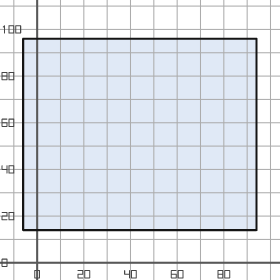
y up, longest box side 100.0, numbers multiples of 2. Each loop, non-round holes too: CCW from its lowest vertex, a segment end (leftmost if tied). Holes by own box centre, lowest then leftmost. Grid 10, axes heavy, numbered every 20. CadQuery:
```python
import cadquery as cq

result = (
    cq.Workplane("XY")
    .moveTo(-6.0, 14.0)
    .lineTo(94.0, 14.0)
    .lineTo(94.0, 96.0)
    .lineTo(-6.0, 96.0)
    .close()
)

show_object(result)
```